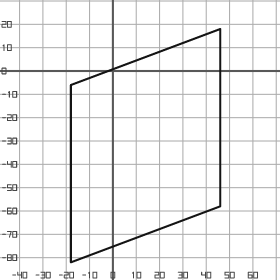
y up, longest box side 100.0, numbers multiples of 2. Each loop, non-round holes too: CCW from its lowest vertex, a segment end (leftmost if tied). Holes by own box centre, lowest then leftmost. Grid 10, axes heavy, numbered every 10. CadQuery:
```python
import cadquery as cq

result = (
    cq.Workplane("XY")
    .moveTo(-18.0, -82.0)
    .lineTo(46.0, -58.0)
    .lineTo(46.0, 18.0)
    .lineTo(-18.0, -6.0)
    .close()
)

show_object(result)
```